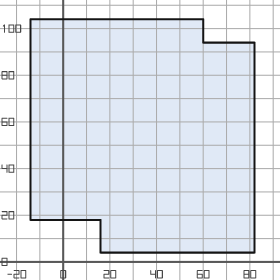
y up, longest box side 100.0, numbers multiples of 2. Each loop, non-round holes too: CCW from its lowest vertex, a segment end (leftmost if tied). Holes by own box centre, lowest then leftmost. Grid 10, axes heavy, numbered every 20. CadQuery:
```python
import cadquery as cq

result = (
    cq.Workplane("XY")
    .moveTo(16.0, 4.0)
    .lineTo(82.0, 4.0)
    .lineTo(82.0, 94.0)
    .lineTo(60.0, 94.0)
    .lineTo(60.0, 104.0)
    .lineTo(-14.0, 104.0)
    .lineTo(-14.0, 18.0)
    .lineTo(16.0, 18.0)
    .close()
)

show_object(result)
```